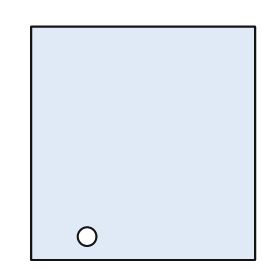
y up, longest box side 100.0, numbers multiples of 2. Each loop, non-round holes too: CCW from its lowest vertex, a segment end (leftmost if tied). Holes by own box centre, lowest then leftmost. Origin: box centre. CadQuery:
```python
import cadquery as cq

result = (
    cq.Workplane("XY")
    .moveTo(-48.0, -50.0)
    .lineTo(48.0, -50.0)
    .lineTo(48.0, 50.0)
    .lineTo(-48.0, 50.0)
    .close()
    .moveTo(-24.0, -40.0)
    .circle(4.0)
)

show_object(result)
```